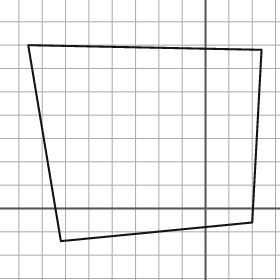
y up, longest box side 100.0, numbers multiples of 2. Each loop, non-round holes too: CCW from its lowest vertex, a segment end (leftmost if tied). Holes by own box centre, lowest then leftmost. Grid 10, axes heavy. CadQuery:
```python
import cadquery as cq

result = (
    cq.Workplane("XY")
    .moveTo(-62.0, -14.0)
    .lineTo(20.0, -6.0)
    .lineTo(24.0, 68.0)
    .lineTo(-76.0, 70.0)
    .close()
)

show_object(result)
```